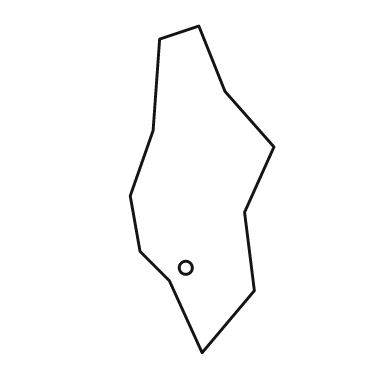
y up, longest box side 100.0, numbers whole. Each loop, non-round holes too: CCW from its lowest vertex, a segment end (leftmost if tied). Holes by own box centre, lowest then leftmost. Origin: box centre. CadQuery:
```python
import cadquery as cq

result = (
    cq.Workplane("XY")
    .moveTo(0.0, -50.0)
    .lineTo(16.0, -31.0)
    .lineTo(13.0, -7.0)
    .lineTo(22.0, 13.0)
    .lineTo(7.0, 30.0)
    .lineTo(-1.0, 50.0)
    .lineTo(-13.0, 46.0)
    .lineTo(-15.0, 18.0)
    .lineTo(-22.0, -2.0)
    .lineTo(-19.0, -19.0)
    .lineTo(-10.0, -28.0)
    .close()
    .moveTo(-5.0, -24.0)
    .circle(2.0)
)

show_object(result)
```